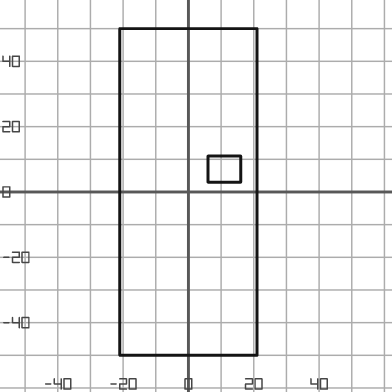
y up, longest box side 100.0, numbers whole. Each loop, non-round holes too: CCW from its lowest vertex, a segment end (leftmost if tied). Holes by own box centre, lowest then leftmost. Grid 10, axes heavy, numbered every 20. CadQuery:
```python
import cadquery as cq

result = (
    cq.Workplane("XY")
    .moveTo(-21.0, -50.0)
    .lineTo(21.0, -50.0)
    .lineTo(21.0, 50.0)
    .lineTo(-21.0, 50.0)
    .close()
    .moveTo(6.0, 3.0)
    .lineTo(16.0, 3.0)
    .lineTo(16.0, 11.0)
    .lineTo(6.0, 11.0)
    .close()
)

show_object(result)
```